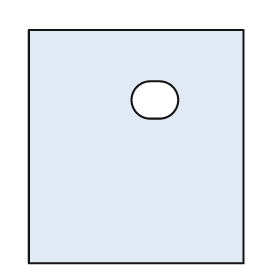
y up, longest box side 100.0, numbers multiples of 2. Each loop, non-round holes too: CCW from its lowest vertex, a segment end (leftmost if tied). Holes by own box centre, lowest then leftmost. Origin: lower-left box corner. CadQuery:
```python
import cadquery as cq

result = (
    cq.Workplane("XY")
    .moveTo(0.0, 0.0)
    .lineTo(92.0, 0.0)
    .lineTo(92.0, 100.0)
    .lineTo(0.0, 100.0)
    .close()
    .moveTo(52.0, 62.0)
    .lineTo(56.0, 62.0)
    .threePointArc((64.0, 70.0), (56.0, 78.0))
    .lineTo(52.0, 78.0)
    .threePointArc((44.0, 70.0), (52.0, 62.0))
    .close()
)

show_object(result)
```